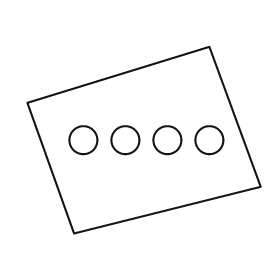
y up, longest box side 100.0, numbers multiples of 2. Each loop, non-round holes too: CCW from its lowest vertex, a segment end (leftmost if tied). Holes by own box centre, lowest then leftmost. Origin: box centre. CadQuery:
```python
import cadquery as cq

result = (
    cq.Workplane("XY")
    .moveTo(-30.0, -40.0)
    .lineTo(50.0, -20.0)
    .lineTo(28.0, 40.0)
    .lineTo(-50.0, 16.0)
    .close()
    .moveTo(-26.0, 0.0)
    .circle(6.0)
    .moveTo(-8.0, 0.0)
    .circle(6.0)
    .moveTo(10.0, 0.0)
    .circle(6.0)
    .moveTo(28.0, 0.0)
    .circle(6.0)
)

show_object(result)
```